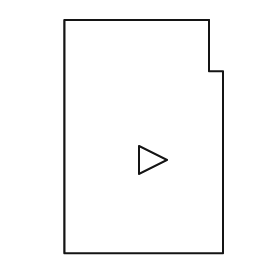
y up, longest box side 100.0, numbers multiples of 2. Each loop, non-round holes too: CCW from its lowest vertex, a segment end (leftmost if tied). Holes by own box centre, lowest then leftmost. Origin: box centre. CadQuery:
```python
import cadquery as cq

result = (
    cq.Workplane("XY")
    .moveTo(-34.0, -50.0)
    .lineTo(34.0, -50.0)
    .lineTo(34.0, 28.0)
    .lineTo(28.0, 28.0)
    .lineTo(28.0, 50.0)
    .lineTo(-34.0, 50.0)
    .close()
    .moveTo(-2.0, -16.0)
    .lineTo(10.0, -10.0)
    .lineTo(-2.0, -4.0)
    .close()
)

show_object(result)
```